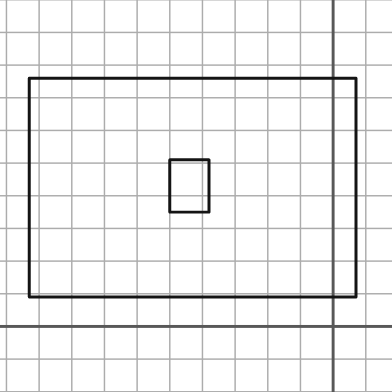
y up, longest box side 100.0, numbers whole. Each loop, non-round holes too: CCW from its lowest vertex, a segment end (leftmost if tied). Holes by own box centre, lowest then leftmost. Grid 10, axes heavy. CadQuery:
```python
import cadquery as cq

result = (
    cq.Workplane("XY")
    .moveTo(-93.0, 9.0)
    .lineTo(7.0, 9.0)
    .lineTo(7.0, 76.0)
    .lineTo(-93.0, 76.0)
    .close()
    .moveTo(-50.0, 35.0)
    .lineTo(-38.0, 35.0)
    .lineTo(-38.0, 51.0)
    .lineTo(-50.0, 51.0)
    .close()
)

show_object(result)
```